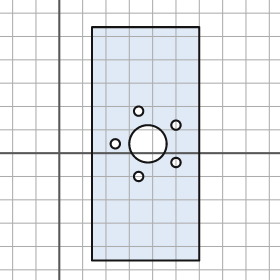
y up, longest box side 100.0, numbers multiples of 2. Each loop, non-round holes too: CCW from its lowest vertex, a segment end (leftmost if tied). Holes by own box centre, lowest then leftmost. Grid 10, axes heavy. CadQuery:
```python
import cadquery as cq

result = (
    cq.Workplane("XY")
    .moveTo(14.0, -46.0)
    .lineTo(60.0, -46.0)
    .lineTo(60.0, 54.0)
    .lineTo(14.0, 54.0)
    .close()
    .moveTo(34.0, -10.0)
    .circle(2.0)
    .moveTo(50.0, -4.0)
    .circle(2.0)
    .moveTo(24.0, 4.0)
    .circle(2.0)
    .moveTo(38.0, 4.0)
    .circle(8.0)
    .moveTo(50.0, 12.0)
    .circle(2.0)
    .moveTo(34.0, 18.0)
    .circle(2.0)
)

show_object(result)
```